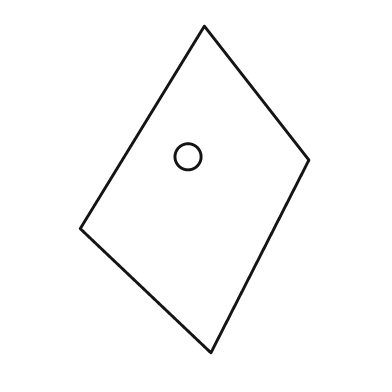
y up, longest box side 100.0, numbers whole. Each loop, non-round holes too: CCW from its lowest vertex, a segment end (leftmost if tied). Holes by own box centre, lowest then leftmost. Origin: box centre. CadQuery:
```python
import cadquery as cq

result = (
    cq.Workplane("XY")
    .moveTo(5.0, -50.0)
    .lineTo(35.0, 9.0)
    .lineTo(3.0, 50.0)
    .lineTo(-35.0, -12.0)
    .close()
    .moveTo(-2.0, 10.0)
    .circle(4.0)
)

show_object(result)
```